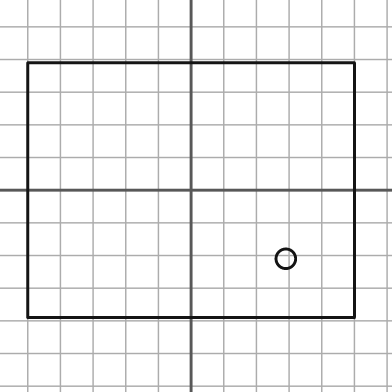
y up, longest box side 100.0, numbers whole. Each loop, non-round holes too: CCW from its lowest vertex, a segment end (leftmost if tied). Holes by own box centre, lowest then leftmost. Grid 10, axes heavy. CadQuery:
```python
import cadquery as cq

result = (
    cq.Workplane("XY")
    .moveTo(-50.0, -39.0)
    .lineTo(50.0, -39.0)
    .lineTo(50.0, 39.0)
    .lineTo(-50.0, 39.0)
    .close()
    .moveTo(29.0, -21.0)
    .circle(3.0)
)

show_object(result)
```